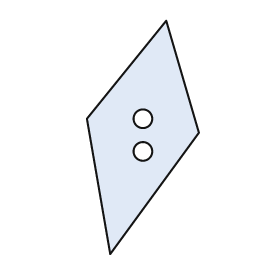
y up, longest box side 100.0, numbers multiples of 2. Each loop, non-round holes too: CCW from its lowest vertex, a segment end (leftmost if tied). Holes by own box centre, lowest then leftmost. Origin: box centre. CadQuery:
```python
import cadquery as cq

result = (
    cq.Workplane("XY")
    .moveTo(-14.0, -50.0)
    .lineTo(24.0, 2.0)
    .lineTo(10.0, 50.0)
    .lineTo(-24.0, 8.0)
    .close()
    .moveTo(0.0, -6.0)
    .circle(4.0)
    .moveTo(0.0, 8.0)
    .circle(4.0)
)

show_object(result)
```